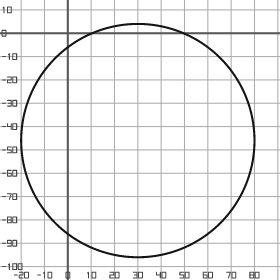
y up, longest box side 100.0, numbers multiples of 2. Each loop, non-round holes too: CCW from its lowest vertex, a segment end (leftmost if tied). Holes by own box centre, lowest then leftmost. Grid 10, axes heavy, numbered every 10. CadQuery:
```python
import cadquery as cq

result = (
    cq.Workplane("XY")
    .moveTo(30.0, -46.0)
    .circle(50.0)
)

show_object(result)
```